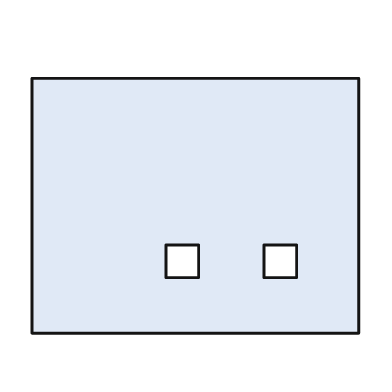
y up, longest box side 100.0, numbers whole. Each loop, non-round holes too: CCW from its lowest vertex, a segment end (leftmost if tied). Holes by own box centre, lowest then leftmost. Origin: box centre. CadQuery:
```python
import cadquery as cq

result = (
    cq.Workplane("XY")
    .moveTo(-50.0, -39.0)
    .lineTo(50.0, -39.0)
    .lineTo(50.0, 39.0)
    .lineTo(-50.0, 39.0)
    .close()
    .moveTo(-9.0, -22.0)
    .lineTo(1.0, -22.0)
    .lineTo(1.0, -12.0)
    .lineTo(-9.0, -12.0)
    .close()
    .moveTo(21.0, -22.0)
    .lineTo(31.0, -22.0)
    .lineTo(31.0, -12.0)
    .lineTo(21.0, -12.0)
    .close()
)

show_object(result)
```